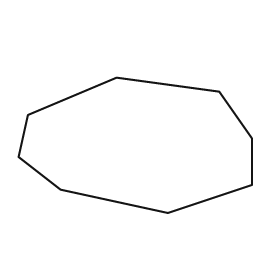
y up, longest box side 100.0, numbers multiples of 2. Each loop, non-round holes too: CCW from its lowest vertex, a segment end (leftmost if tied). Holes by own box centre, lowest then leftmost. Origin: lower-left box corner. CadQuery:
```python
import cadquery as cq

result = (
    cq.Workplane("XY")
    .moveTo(64.0, 0.0)
    .lineTo(100.0, 12.0)
    .lineTo(100.0, 32.0)
    .lineTo(86.0, 52.0)
    .lineTo(42.0, 58.0)
    .lineTo(4.0, 42.0)
    .lineTo(0.0, 24.0)
    .lineTo(18.0, 10.0)
    .close()
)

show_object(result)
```